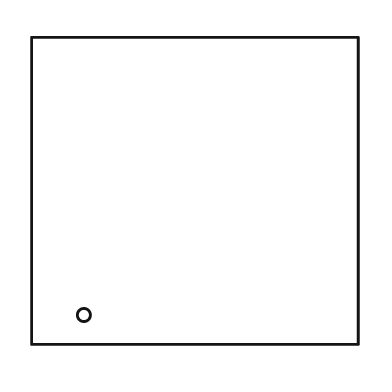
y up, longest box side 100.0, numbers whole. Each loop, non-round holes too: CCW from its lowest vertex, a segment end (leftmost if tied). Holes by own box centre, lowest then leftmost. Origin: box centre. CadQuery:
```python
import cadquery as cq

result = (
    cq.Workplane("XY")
    .moveTo(-50.0, -47.0)
    .lineTo(50.0, -47.0)
    .lineTo(50.0, 47.0)
    .lineTo(-50.0, 47.0)
    .close()
    .moveTo(-34.0, -38.0)
    .circle(2.0)
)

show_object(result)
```